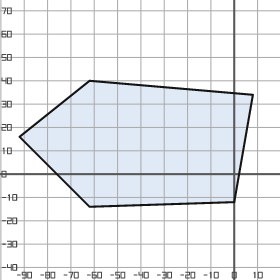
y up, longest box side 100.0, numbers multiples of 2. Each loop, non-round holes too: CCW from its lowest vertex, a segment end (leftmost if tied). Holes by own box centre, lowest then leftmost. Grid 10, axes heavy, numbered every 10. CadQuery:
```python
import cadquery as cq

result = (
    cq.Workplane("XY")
    .moveTo(-62.0, -14.0)
    .lineTo(0.0, -12.0)
    .lineTo(8.0, 34.0)
    .lineTo(-62.0, 40.0)
    .lineTo(-92.0, 16.0)
    .close()
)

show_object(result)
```